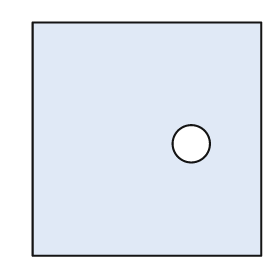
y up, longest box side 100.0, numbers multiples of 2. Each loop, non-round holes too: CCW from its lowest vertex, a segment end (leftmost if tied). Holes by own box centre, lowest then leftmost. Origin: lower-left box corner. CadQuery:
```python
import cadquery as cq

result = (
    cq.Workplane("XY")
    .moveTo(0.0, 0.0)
    .lineTo(98.0, 0.0)
    .lineTo(98.0, 100.0)
    .lineTo(0.0, 100.0)
    .close()
    .moveTo(68.0, 48.0)
    .circle(8.0)
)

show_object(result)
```